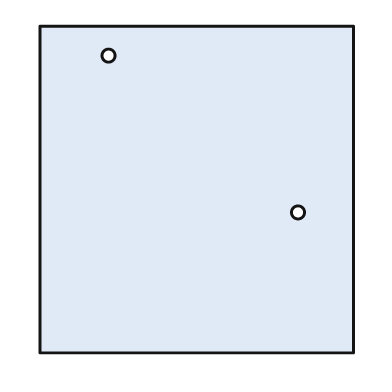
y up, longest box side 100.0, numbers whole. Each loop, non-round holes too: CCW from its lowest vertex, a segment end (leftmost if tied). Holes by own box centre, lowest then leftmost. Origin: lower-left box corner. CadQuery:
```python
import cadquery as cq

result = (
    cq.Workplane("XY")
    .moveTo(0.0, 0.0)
    .lineTo(96.0, 0.0)
    .lineTo(96.0, 100.0)
    .lineTo(0.0, 100.0)
    .close()
    .moveTo(79.0, 43.0)
    .circle(2.0)
    .moveTo(21.0, 91.0)
    .circle(2.0)
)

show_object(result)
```